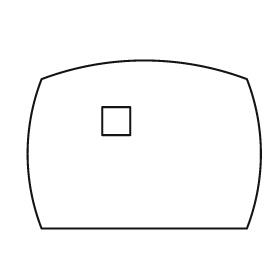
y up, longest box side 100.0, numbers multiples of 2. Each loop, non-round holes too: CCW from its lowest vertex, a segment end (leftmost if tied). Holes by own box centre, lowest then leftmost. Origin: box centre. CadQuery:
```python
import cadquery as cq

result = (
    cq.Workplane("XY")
    .moveTo(-44.0, -36.0)
    .lineTo(44.0, -36.0)
    .threePointArc((50.0, -4.0), (44.0, 28.0))
    .threePointArc((0.0, 36.0), (-44.0, 28.0))
    .threePointArc((-50.0, -4.0), (-44.0, -36.0))
    .close()
    .moveTo(-18.0, 4.0)
    .lineTo(-6.0, 4.0)
    .lineTo(-6.0, 16.0)
    .lineTo(-18.0, 16.0)
    .close()
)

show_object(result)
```